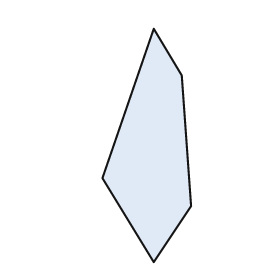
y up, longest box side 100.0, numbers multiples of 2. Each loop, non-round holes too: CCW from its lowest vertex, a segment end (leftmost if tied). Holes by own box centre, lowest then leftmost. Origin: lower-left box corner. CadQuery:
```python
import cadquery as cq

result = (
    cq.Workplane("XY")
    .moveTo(22.0, 0.0)
    .lineTo(38.0, 24.0)
    .lineTo(34.0, 80.0)
    .lineTo(22.0, 100.0)
    .lineTo(0.0, 36.0)
    .close()
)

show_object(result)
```